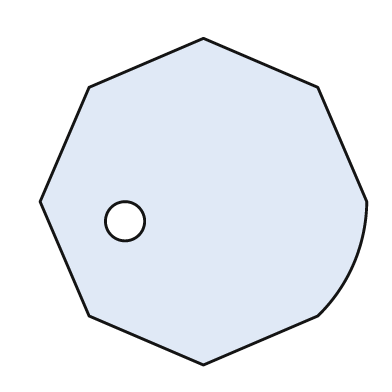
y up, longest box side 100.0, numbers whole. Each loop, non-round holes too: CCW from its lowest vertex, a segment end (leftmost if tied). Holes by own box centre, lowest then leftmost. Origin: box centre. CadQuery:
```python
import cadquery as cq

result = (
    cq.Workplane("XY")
    .moveTo(0.0, -50.0)
    .lineTo(35.0, -35.0)
    .threePointArc((46.0, -19.0), (50.0, 0.0))
    .lineTo(35.0, 35.0)
    .lineTo(0.0, 50.0)
    .lineTo(-35.0, 35.0)
    .lineTo(-50.0, 0.0)
    .lineTo(-35.0, -35.0)
    .close()
    .moveTo(-24.0, -6.0)
    .circle(6.0)
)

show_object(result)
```